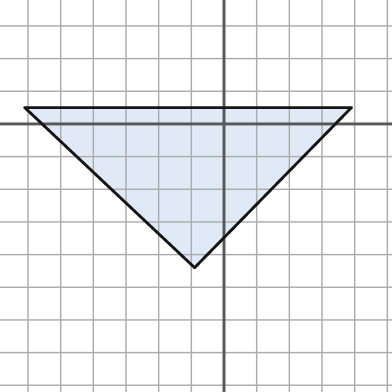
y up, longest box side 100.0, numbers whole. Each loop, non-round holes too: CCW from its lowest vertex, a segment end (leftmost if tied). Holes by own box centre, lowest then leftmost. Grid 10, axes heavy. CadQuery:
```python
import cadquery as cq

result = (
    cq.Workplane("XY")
    .moveTo(-9.0, -44.0)
    .lineTo(39.0, 5.0)
    .lineTo(-61.0, 5.0)
    .close()
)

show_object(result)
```